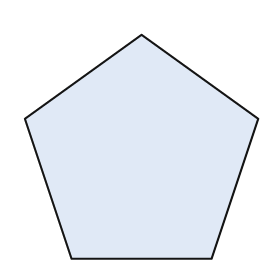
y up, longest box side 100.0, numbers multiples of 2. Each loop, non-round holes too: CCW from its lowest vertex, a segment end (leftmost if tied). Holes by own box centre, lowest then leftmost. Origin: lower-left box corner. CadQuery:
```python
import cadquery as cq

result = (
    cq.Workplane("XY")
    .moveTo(20.0, 0.0)
    .lineTo(80.0, 0.0)
    .lineTo(100.0, 60.0)
    .lineTo(50.0, 96.0)
    .lineTo(0.0, 60.0)
    .close()
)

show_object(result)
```